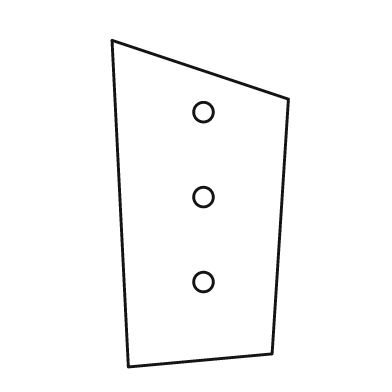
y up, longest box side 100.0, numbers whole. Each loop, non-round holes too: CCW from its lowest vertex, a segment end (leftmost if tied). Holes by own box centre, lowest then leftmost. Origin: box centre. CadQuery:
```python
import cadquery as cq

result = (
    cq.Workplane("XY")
    .moveTo(-22.0, -50.0)
    .lineTo(22.0, -46.0)
    .lineTo(27.0, 32.0)
    .lineTo(-27.0, 50.0)
    .close()
    .moveTo(1.0, -24.0)
    .circle(3.0)
    .moveTo(1.0, 2.0)
    .circle(3.0)
    .moveTo(1.0, 28.0)
    .circle(3.0)
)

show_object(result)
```